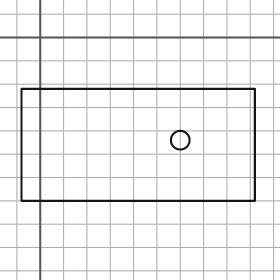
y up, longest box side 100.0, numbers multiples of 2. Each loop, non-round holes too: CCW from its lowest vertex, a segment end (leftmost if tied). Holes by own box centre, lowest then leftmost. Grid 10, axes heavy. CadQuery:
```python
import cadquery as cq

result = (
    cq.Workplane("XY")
    .moveTo(-8.0, -70.0)
    .lineTo(92.0, -70.0)
    .lineTo(92.0, -22.0)
    .lineTo(-8.0, -22.0)
    .close()
    .moveTo(60.0, -44.0)
    .circle(4.0)
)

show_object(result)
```